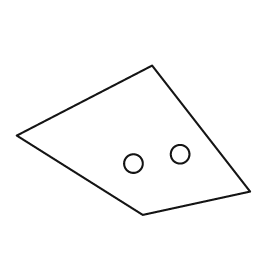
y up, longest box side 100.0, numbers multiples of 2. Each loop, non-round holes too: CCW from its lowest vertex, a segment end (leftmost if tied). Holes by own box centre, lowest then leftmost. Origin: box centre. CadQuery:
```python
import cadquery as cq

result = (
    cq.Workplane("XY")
    .moveTo(4.0, -32.0)
    .lineTo(50.0, -22.0)
    .lineTo(8.0, 32.0)
    .lineTo(-50.0, 2.0)
    .close()
    .moveTo(0.0, -10.0)
    .circle(4.0)
    .moveTo(20.0, -6.0)
    .circle(4.0)
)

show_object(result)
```